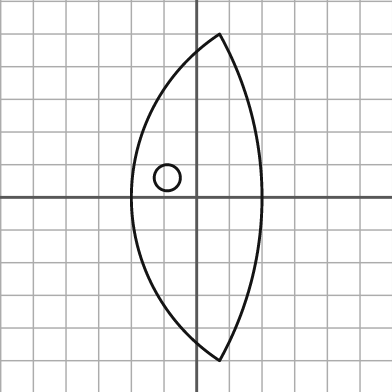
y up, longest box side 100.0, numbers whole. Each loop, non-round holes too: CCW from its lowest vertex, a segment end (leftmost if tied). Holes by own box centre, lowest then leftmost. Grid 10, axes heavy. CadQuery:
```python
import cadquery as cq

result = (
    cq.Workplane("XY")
    .moveTo(7.0, -50.0)
    .threePointArc((20.0, 0.0), (7.0, 50.0))
    .threePointArc((-20.0, 0.0), (7.0, -50.0))
    .close()
    .moveTo(-9.0, 6.0)
    .circle(4.0)
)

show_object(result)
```